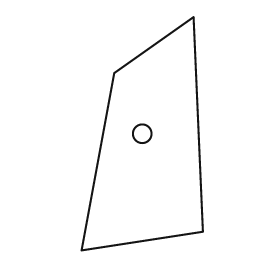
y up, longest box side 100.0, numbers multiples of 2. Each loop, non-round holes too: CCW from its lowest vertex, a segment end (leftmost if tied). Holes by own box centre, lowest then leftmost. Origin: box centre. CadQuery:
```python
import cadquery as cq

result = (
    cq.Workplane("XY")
    .moveTo(-26.0, -50.0)
    .lineTo(26.0, -42.0)
    .lineTo(22.0, 50.0)
    .lineTo(-12.0, 26.0)
    .close()
    .moveTo(0.0, 0.0)
    .circle(4.0)
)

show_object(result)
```